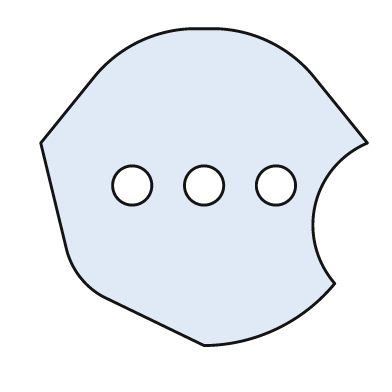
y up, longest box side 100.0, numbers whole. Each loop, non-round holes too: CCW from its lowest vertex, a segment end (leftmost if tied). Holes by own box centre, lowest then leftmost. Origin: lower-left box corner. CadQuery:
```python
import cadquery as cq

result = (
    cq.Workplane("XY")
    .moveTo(50.0, 0.0)
    .threePointArc((72.0, 5.0), (90.0, 19.0))
    .threePointArc((84.0, 43.0), (100.0, 62.0))
    .lineTo(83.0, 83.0)
    .threePointArc((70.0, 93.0), (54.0, 97.0))
    .lineTo(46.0, 97.0)
    .threePointArc((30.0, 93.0), (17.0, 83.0))
    .lineTo(0.0, 62.0)
    .lineTo(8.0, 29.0)
    .threePointArc((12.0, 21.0), (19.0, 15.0))
    .close()
    .moveTo(28.0, 49.0)
    .circle(6.0)
    .moveTo(50.0, 49.0)
    .circle(6.0)
    .moveTo(72.0, 49.0)
    .circle(6.0)
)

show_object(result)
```